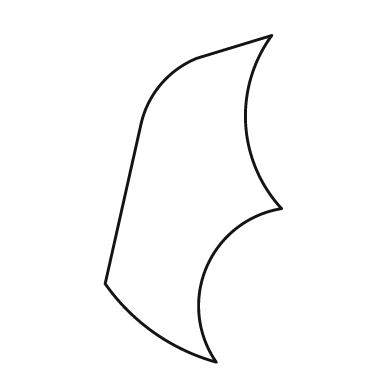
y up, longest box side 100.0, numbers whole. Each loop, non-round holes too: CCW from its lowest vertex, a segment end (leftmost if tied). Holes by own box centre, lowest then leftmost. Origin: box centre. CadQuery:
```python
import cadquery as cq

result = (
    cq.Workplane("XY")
    .moveTo(7.0, -50.0)
    .threePointArc((4.0, -21.0), (27.0, -3.0))
    .threePointArc((16.0, 23.0), (24.0, 50.0))
    .lineTo(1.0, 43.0)
    .threePointArc((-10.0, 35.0), (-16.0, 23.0))
    .lineTo(-27.0, -26.0)
    .threePointArc((-12.0, -41.0), (7.0, -50.0))
    .close()
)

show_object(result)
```